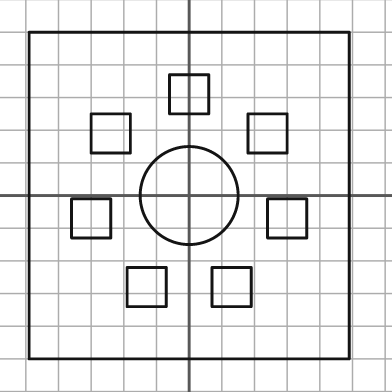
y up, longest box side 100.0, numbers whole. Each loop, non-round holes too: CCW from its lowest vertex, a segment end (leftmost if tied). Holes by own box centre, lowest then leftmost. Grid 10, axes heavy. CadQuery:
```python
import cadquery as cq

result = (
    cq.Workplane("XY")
    .moveTo(-49.0, -50.0)
    .lineTo(49.0, -50.0)
    .lineTo(49.0, 50.0)
    .lineTo(-49.0, 50.0)
    .close()
    .moveTo(-19.0, -34.0)
    .lineTo(-7.0, -34.0)
    .lineTo(-7.0, -22.0)
    .lineTo(-19.0, -22.0)
    .close()
    .moveTo(7.0, -34.0)
    .lineTo(19.0, -34.0)
    .lineTo(19.0, -22.0)
    .lineTo(7.0, -22.0)
    .close()
    .moveTo(-36.0, -13.0)
    .lineTo(-24.0, -13.0)
    .lineTo(-24.0, -1.0)
    .lineTo(-36.0, -1.0)
    .close()
    .moveTo(24.0, -13.0)
    .lineTo(36.0, -13.0)
    .lineTo(36.0, -1.0)
    .lineTo(24.0, -1.0)
    .close()
    .moveTo(0.0, 0.0)
    .circle(15.0)
    .moveTo(-30.0, 13.0)
    .lineTo(-18.0, 13.0)
    .lineTo(-18.0, 25.0)
    .lineTo(-30.0, 25.0)
    .close()
    .moveTo(18.0, 13.0)
    .lineTo(30.0, 13.0)
    .lineTo(30.0, 25.0)
    .lineTo(18.0, 25.0)
    .close()
    .moveTo(-6.0, 25.0)
    .lineTo(6.0, 25.0)
    .lineTo(6.0, 37.0)
    .lineTo(-6.0, 37.0)
    .close()
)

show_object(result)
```